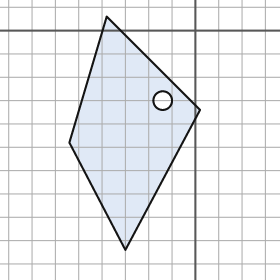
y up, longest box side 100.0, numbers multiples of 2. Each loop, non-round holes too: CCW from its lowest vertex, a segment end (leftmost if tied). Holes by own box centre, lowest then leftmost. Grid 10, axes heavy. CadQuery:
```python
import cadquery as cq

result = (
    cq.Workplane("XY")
    .moveTo(-30.0, -94.0)
    .lineTo(2.0, -34.0)
    .lineTo(-38.0, 6.0)
    .lineTo(-54.0, -48.0)
    .close()
    .moveTo(-14.0, -30.0)
    .circle(4.0)
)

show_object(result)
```